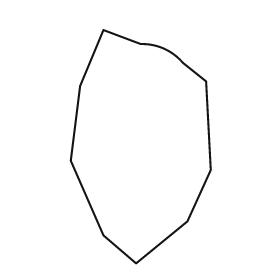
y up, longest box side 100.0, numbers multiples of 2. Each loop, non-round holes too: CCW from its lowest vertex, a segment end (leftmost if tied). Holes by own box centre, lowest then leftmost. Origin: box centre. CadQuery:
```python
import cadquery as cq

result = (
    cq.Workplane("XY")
    .moveTo(-2.0, -50.0)
    .lineTo(20.0, -32.0)
    .lineTo(30.0, -10.0)
    .lineTo(28.0, 28.0)
    .lineTo(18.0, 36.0)
    .threePointArc((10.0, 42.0), (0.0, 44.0))
    .lineTo(-16.0, 50.0)
    .lineTo(-26.0, 26.0)
    .lineTo(-30.0, -6.0)
    .lineTo(-16.0, -38.0)
    .close()
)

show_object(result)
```